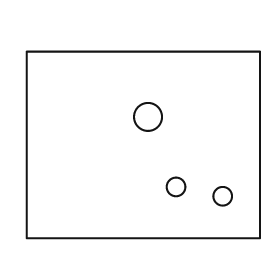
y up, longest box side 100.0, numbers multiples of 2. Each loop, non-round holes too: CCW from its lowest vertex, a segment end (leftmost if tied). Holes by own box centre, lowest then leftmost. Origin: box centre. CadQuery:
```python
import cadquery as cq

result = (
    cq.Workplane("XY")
    .moveTo(-50.0, -40.0)
    .lineTo(50.0, -40.0)
    .lineTo(50.0, 40.0)
    .lineTo(-50.0, 40.0)
    .close()
    .moveTo(34.0, -22.0)
    .circle(4.0)
    .moveTo(14.0, -18.0)
    .circle(4.0)
    .moveTo(2.0, 12.0)
    .circle(6.0)
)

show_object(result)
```